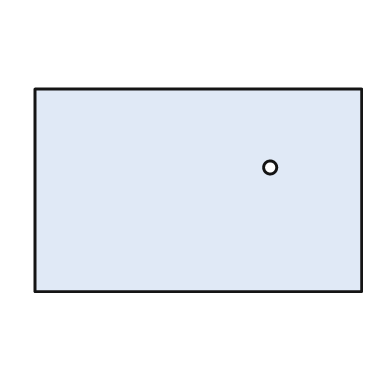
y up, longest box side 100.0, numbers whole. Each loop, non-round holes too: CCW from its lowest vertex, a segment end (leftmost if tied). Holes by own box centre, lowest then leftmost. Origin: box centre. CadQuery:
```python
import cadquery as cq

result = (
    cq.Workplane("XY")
    .moveTo(-50.0, -31.0)
    .lineTo(50.0, -31.0)
    .lineTo(50.0, 31.0)
    .lineTo(-50.0, 31.0)
    .close()
    .moveTo(22.0, 7.0)
    .circle(2.0)
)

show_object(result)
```